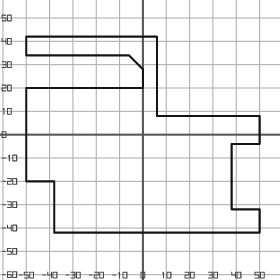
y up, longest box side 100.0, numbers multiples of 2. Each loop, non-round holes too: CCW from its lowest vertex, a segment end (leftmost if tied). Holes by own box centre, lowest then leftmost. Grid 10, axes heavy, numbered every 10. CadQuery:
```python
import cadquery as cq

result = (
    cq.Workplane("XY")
    .moveTo(-38.0, -42.0)
    .lineTo(50.0, -42.0)
    .lineTo(50.0, -32.0)
    .lineTo(38.0, -32.0)
    .lineTo(38.0, -4.0)
    .lineTo(50.0, -4.0)
    .lineTo(50.0, 8.0)
    .lineTo(6.0, 8.0)
    .lineTo(6.0, 42.0)
    .lineTo(-50.0, 42.0)
    .lineTo(-50.0, 34.0)
    .lineTo(-6.0, 34.0)
    .lineTo(0.0, 28.0)
    .lineTo(0.0, 20.0)
    .lineTo(-50.0, 20.0)
    .lineTo(-50.0, -20.0)
    .lineTo(-38.0, -20.0)
    .close()
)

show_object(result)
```